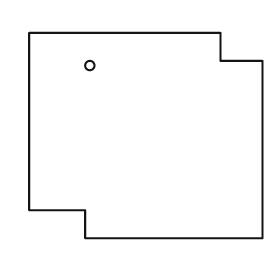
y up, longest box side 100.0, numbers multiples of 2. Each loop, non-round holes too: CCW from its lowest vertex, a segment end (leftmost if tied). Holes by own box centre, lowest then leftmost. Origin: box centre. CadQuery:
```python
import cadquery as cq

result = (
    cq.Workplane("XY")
    .moveTo(-26.0, -44.0)
    .lineTo(50.0, -44.0)
    .lineTo(50.0, 32.0)
    .lineTo(32.0, 32.0)
    .lineTo(32.0, 44.0)
    .lineTo(-50.0, 44.0)
    .lineTo(-50.0, -32.0)
    .lineTo(-26.0, -32.0)
    .close()
    .moveTo(-24.0, 30.0)
    .circle(2.0)
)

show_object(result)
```